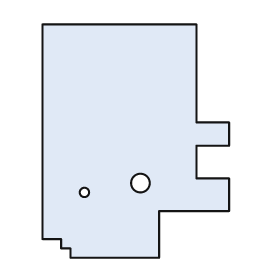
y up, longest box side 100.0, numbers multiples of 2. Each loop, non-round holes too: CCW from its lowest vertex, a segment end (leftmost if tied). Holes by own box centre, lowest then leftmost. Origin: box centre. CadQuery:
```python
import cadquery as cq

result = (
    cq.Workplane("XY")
    .moveTo(-28.0, -50.0)
    .lineTo(10.0, -50.0)
    .lineTo(10.0, -30.0)
    .lineTo(40.0, -30.0)
    .lineTo(40.0, -16.0)
    .lineTo(26.0, -16.0)
    .lineTo(26.0, -2.0)
    .lineTo(40.0, -2.0)
    .lineTo(40.0, 8.0)
    .lineTo(26.0, 8.0)
    .lineTo(26.0, 50.0)
    .lineTo(-40.0, 50.0)
    .lineTo(-40.0, -42.0)
    .lineTo(-32.0, -42.0)
    .lineTo(-32.0, -46.0)
    .lineTo(-28.0, -46.0)
    .close()
    .moveTo(-22.0, -22.0)
    .circle(2.0)
    .moveTo(2.0, -18.0)
    .circle(4.0)
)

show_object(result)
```